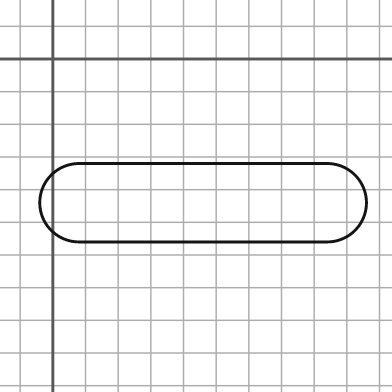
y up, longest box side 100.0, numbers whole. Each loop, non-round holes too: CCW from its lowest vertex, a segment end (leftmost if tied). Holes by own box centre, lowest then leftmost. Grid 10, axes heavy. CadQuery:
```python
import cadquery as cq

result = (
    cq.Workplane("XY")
    .moveTo(8.0, -56.0)
    .lineTo(84.0, -56.0)
    .threePointArc((96.0, -44.0), (84.0, -32.0))
    .lineTo(8.0, -32.0)
    .threePointArc((-4.0, -44.0), (8.0, -56.0))
    .close()
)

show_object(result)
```